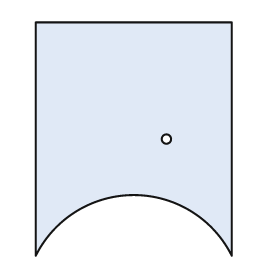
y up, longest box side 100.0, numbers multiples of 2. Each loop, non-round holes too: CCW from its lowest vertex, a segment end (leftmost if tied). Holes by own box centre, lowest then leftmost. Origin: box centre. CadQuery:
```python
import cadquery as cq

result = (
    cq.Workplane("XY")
    .moveTo(-42.0, -50.0)
    .threePointArc((0.0, -24.0), (42.0, -50.0))
    .lineTo(42.0, 50.0)
    .lineTo(-42.0, 50.0)
    .close()
    .moveTo(14.0, 0.0)
    .circle(2.0)
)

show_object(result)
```